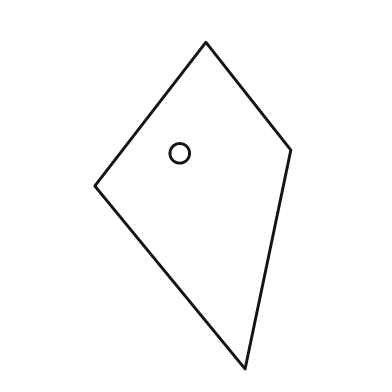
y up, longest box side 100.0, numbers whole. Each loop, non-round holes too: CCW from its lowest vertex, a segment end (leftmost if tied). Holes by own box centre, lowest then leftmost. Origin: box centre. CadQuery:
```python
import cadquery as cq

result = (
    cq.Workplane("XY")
    .moveTo(16.0, -50.0)
    .lineTo(30.0, 17.0)
    .lineTo(4.0, 50.0)
    .lineTo(-30.0, 6.0)
    .close()
    .moveTo(-4.0, 16.0)
    .circle(3.0)
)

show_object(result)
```